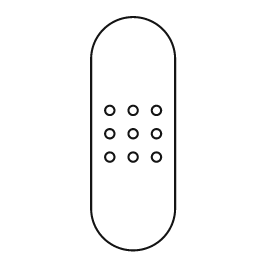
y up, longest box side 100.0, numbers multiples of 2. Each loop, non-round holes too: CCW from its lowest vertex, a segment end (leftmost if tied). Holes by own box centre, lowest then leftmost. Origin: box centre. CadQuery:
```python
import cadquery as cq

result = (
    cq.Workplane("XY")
    .moveTo(-18.0, -32.0)
    .threePointArc((0.0, -50.0), (18.0, -32.0))
    .lineTo(18.0, 32.0)
    .threePointArc((0.0, 50.0), (-18.0, 32.0))
    .close()
    .moveTo(-10.0, -10.0)
    .circle(2.0)
    .moveTo(0.0, -10.0)
    .circle(2.0)
    .moveTo(10.0, -10.0)
    .circle(2.0)
    .moveTo(-10.0, 0.0)
    .circle(2.0)
    .moveTo(0.0, 0.0)
    .circle(2.0)
    .moveTo(10.0, 0.0)
    .circle(2.0)
    .moveTo(-10.0, 10.0)
    .circle(2.0)
    .moveTo(0.0, 10.0)
    .circle(2.0)
    .moveTo(10.0, 10.0)
    .circle(2.0)
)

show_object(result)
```